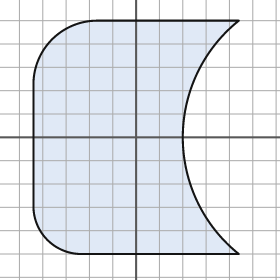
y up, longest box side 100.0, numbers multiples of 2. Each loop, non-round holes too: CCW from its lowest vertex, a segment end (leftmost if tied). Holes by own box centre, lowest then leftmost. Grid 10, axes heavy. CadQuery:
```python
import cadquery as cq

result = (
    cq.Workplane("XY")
    .moveTo(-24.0, -50.0)
    .lineTo(44.0, -50.0)
    .threePointArc((20.0, 0.0), (44.0, 50.0))
    .lineTo(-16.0, 50.0)
    .threePointArc((-36.0, 42.0), (-44.0, 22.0))
    .lineTo(-44.0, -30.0)
    .threePointArc((-38.0, -44.0), (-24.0, -50.0))
    .close()
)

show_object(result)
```